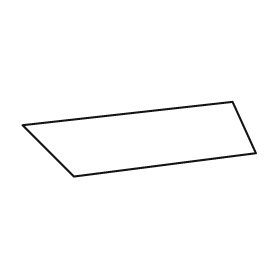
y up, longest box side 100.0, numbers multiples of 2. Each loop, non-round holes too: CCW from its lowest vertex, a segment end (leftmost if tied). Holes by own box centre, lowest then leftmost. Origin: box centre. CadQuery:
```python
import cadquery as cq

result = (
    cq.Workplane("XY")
    .moveTo(-28.0, -16.0)
    .lineTo(50.0, -6.0)
    .lineTo(40.0, 16.0)
    .lineTo(-50.0, 6.0)
    .close()
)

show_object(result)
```